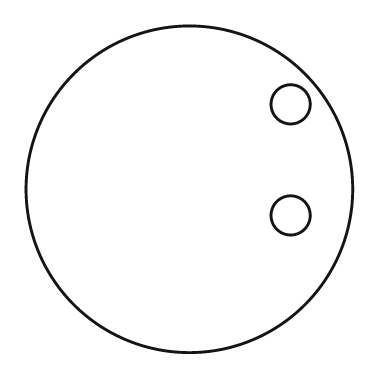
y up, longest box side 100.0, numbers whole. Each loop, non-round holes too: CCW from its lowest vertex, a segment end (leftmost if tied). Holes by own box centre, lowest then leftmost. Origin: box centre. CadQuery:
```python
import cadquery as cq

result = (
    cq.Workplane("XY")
    .moveTo(0.0, 0.0)
    .circle(50.0)
    .moveTo(31.0, -8.0)
    .circle(6.0)
    .moveTo(31.0, 26.0)
    .circle(6.0)
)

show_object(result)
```